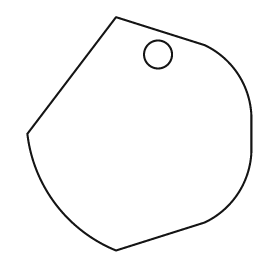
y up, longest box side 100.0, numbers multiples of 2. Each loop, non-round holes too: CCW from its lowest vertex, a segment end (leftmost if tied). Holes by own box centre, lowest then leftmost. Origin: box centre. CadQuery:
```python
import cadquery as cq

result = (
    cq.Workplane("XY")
    .moveTo(-10.0, -50.0)
    .lineTo(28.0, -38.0)
    .threePointArc((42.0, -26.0), (48.0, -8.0))
    .lineTo(48.0, 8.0)
    .threePointArc((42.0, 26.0), (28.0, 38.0))
    .lineTo(-10.0, 50.0)
    .lineTo(-48.0, 0.0)
    .threePointArc((-36.0, -30.0), (-10.0, -50.0))
    .close()
    .moveTo(8.0, 34.0)
    .circle(6.0)
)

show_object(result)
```